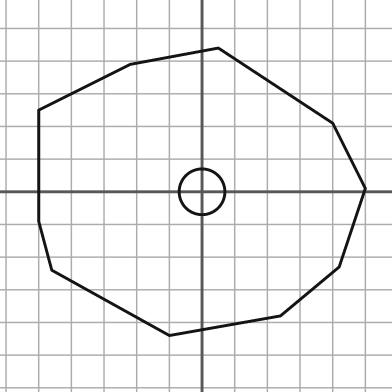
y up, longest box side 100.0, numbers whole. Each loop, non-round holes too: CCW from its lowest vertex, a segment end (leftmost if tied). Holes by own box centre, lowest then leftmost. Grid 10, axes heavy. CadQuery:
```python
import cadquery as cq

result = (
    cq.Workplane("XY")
    .moveTo(-10.0, -44.0)
    .lineTo(24.0, -38.0)
    .lineTo(42.0, -23.0)
    .lineTo(50.0, 1.0)
    .lineTo(40.0, 21.0)
    .lineTo(5.0, 44.0)
    .lineTo(-22.0, 39.0)
    .lineTo(-50.0, 25.0)
    .lineTo(-50.0, -9.0)
    .lineTo(-46.0, -24.0)
    .close()
    .moveTo(0.0, 0.0)
    .circle(7.0)
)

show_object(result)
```